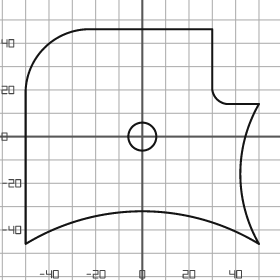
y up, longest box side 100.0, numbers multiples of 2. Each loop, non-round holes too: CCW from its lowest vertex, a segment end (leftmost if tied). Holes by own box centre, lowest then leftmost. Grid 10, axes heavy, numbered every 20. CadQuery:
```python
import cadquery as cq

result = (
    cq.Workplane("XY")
    .moveTo(-50.0, -46.0)
    .threePointArc((0.0, -32.0), (50.0, -46.0))
    .threePointArc((42.0, -16.0), (50.0, 14.0))
    .lineTo(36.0, 14.0)
    .threePointArc((32.0, 16.0), (30.0, 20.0))
    .lineTo(30.0, 46.0)
    .lineTo(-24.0, 46.0)
    .threePointArc((-42.0, 38.0), (-50.0, 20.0))
    .close()
    .moveTo(0.0, 0.0)
    .circle(6.0)
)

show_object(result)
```